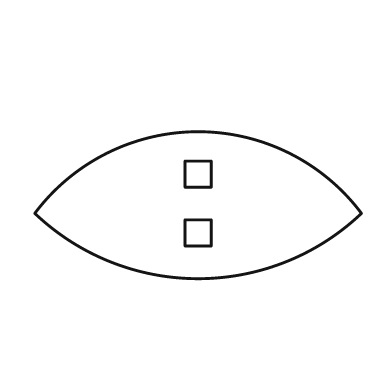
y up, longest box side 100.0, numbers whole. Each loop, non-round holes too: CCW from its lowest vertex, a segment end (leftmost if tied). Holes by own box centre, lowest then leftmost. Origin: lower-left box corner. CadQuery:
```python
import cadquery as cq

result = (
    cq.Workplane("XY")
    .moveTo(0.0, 20.0)
    .threePointArc((50.0, 0.0), (100.0, 20.0))
    .threePointArc((50.0, 45.0), (0.0, 20.0))
    .close()
    .moveTo(46.0, 10.0)
    .lineTo(54.0, 10.0)
    .lineTo(54.0, 18.0)
    .lineTo(46.0, 18.0)
    .close()
    .moveTo(46.0, 28.0)
    .lineTo(54.0, 28.0)
    .lineTo(54.0, 36.0)
    .lineTo(46.0, 36.0)
    .close()
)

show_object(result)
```